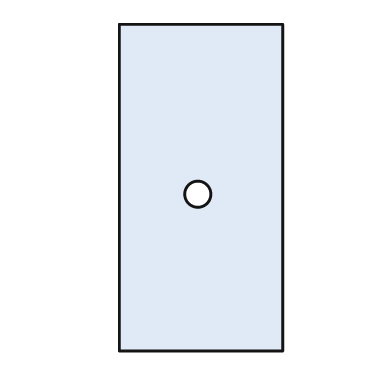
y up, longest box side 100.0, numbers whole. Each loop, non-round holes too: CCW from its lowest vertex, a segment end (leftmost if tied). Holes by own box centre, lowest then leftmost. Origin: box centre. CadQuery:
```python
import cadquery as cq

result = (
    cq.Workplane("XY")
    .moveTo(-25.0, -50.0)
    .lineTo(25.0, -50.0)
    .lineTo(25.0, 50.0)
    .lineTo(-25.0, 50.0)
    .close()
    .moveTo(-1.0, -2.0)
    .circle(4.0)
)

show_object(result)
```